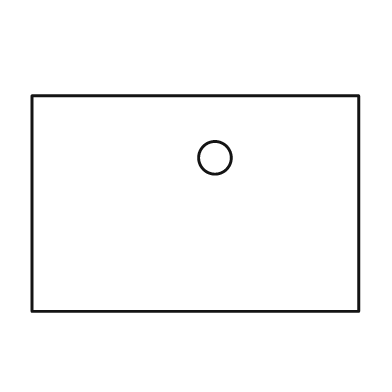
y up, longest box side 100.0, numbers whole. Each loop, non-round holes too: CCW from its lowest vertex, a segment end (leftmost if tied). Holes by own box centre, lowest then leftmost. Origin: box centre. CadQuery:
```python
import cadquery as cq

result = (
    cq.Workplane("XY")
    .moveTo(-50.0, -33.0)
    .lineTo(50.0, -33.0)
    .lineTo(50.0, 33.0)
    .lineTo(-50.0, 33.0)
    .close()
    .moveTo(6.0, 14.0)
    .circle(5.0)
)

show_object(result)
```